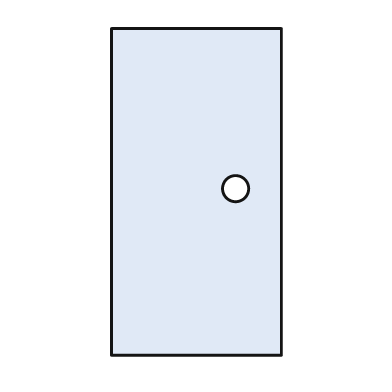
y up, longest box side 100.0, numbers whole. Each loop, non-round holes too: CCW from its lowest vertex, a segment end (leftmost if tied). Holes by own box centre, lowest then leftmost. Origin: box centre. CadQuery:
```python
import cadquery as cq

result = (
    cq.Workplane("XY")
    .moveTo(-26.0, -50.0)
    .lineTo(26.0, -50.0)
    .lineTo(26.0, 50.0)
    .lineTo(-26.0, 50.0)
    .close()
    .moveTo(12.0, 1.0)
    .circle(4.0)
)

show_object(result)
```